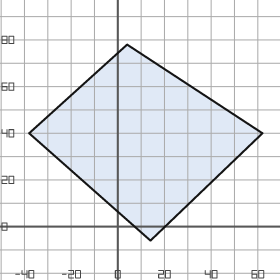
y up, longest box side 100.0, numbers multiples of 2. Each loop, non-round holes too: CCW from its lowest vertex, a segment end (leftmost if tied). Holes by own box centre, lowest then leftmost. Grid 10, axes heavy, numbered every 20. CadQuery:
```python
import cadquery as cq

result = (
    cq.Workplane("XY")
    .moveTo(14.0, -6.0)
    .lineTo(62.0, 40.0)
    .lineTo(4.0, 78.0)
    .lineTo(-38.0, 40.0)
    .close()
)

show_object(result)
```